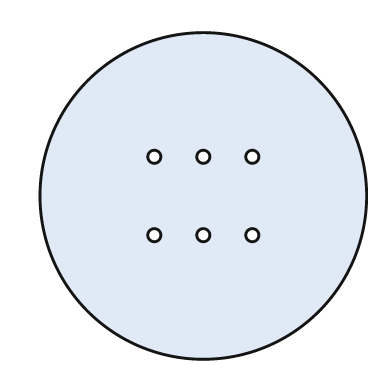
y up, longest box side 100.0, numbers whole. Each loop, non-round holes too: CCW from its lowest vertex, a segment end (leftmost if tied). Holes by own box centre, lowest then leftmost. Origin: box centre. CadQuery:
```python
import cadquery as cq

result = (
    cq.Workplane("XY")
    .moveTo(0.0, 0.0)
    .circle(50.0)
    .moveTo(-15.0, -12.0)
    .circle(2.0)
    .moveTo(0.0, -12.0)
    .circle(2.0)
    .moveTo(15.0, -12.0)
    .circle(2.0)
    .moveTo(-15.0, 12.0)
    .circle(2.0)
    .moveTo(0.0, 12.0)
    .circle(2.0)
    .moveTo(15.0, 12.0)
    .circle(2.0)
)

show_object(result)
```